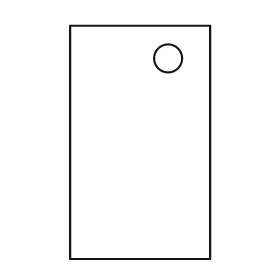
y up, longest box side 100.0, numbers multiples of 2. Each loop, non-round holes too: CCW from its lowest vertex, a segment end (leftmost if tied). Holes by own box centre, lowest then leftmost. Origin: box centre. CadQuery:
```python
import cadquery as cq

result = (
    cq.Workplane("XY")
    .moveTo(-30.0, -50.0)
    .lineTo(30.0, -50.0)
    .lineTo(30.0, 50.0)
    .lineTo(-30.0, 50.0)
    .close()
    .moveTo(12.0, 36.0)
    .circle(6.0)
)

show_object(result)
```